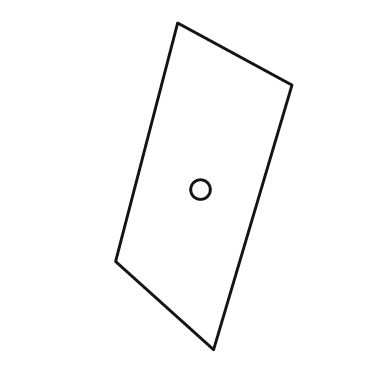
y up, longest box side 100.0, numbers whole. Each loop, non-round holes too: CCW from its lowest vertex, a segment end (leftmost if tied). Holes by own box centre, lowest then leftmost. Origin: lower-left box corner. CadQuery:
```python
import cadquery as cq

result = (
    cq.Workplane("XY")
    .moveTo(30.0, 0.0)
    .lineTo(54.0, 81.0)
    .lineTo(19.0, 100.0)
    .lineTo(0.0, 27.0)
    .close()
    .moveTo(26.0, 49.0)
    .circle(3.0)
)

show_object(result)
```